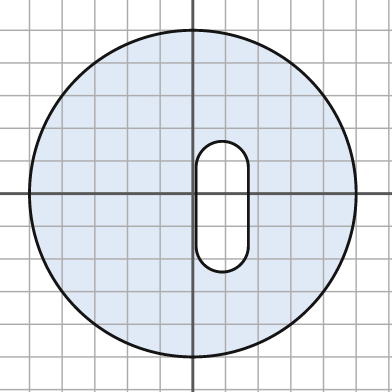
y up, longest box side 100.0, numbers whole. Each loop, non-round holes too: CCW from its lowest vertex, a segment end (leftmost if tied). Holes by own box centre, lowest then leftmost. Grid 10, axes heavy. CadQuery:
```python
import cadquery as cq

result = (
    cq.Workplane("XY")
    .moveTo(0.0, 0.0)
    .circle(50.0)
    .moveTo(1.0, -16.0)
    .threePointArc((9.0, -24.0), (17.0, -16.0))
    .lineTo(17.0, 8.0)
    .threePointArc((9.0, 16.0), (1.0, 8.0))
    .close()
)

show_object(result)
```